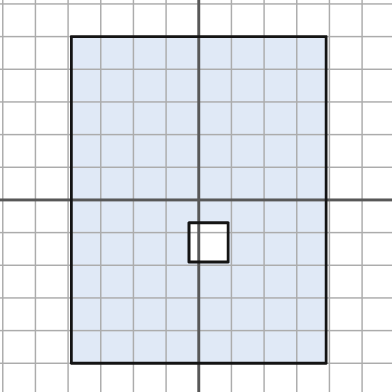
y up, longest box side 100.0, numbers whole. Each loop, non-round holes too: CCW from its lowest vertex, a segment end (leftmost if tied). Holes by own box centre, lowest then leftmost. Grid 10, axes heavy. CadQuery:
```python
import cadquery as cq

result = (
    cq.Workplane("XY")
    .moveTo(-39.0, -50.0)
    .lineTo(39.0, -50.0)
    .lineTo(39.0, 50.0)
    .lineTo(-39.0, 50.0)
    .close()
    .moveTo(-3.0, -19.0)
    .lineTo(9.0, -19.0)
    .lineTo(9.0, -7.0)
    .lineTo(-3.0, -7.0)
    .close()
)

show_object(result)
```